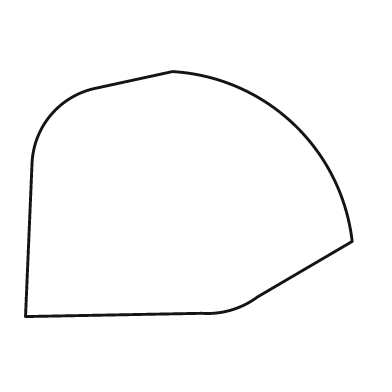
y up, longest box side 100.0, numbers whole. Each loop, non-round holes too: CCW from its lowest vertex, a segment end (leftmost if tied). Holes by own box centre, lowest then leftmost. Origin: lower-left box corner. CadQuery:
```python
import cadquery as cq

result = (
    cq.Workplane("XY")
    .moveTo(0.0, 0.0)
    .lineTo(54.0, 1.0)
    .threePointArc((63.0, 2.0), (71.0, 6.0))
    .lineTo(100.0, 23.0)
    .threePointArc((82.0, 59.0), (45.0, 75.0))
    .lineTo(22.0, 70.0)
    .threePointArc((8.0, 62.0), (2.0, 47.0))
    .close()
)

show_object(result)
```